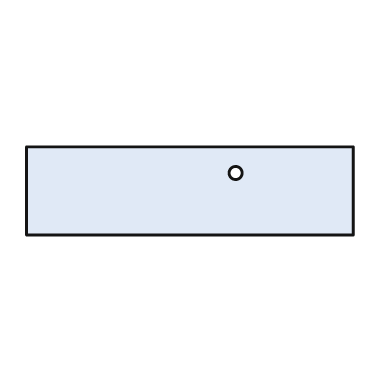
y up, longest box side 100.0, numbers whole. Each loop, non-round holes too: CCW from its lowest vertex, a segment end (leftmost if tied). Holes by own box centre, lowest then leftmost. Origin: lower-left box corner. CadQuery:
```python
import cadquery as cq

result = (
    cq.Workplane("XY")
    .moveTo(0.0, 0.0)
    .lineTo(100.0, 0.0)
    .lineTo(100.0, 27.0)
    .lineTo(0.0, 27.0)
    .close()
    .moveTo(64.0, 19.0)
    .circle(2.0)
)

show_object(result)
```